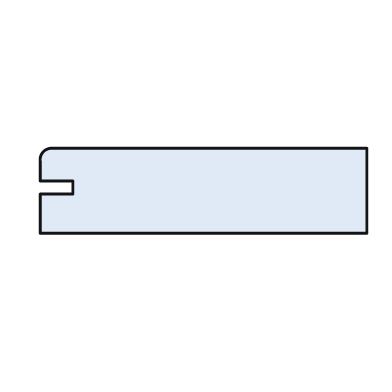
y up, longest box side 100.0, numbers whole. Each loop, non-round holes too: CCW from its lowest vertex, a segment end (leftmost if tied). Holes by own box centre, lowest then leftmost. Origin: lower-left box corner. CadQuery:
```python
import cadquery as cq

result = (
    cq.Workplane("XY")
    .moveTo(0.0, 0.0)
    .lineTo(100.0, 0.0)
    .lineTo(100.0, 26.0)
    .lineTo(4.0, 26.0)
    .threePointArc((1.0, 25.0), (0.0, 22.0))
    .lineTo(0.0, 16.0)
    .lineTo(10.0, 16.0)
    .lineTo(10.0, 12.0)
    .lineTo(0.0, 12.0)
    .close()
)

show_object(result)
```